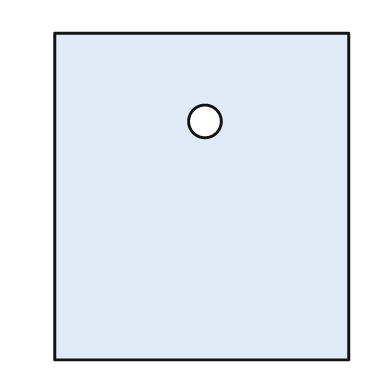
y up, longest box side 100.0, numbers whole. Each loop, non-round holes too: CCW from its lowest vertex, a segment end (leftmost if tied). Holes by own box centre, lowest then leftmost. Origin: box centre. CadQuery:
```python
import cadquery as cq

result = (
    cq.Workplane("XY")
    .moveTo(-45.0, -50.0)
    .lineTo(45.0, -50.0)
    .lineTo(45.0, 50.0)
    .lineTo(-45.0, 50.0)
    .close()
    .moveTo(1.0, 23.0)
    .circle(5.0)
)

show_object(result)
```